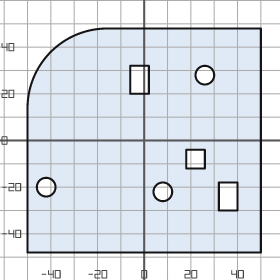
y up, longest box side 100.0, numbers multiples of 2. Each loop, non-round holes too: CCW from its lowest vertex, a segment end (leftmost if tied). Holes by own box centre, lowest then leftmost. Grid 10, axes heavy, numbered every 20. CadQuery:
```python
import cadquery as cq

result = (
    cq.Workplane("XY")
    .moveTo(-50.0, -48.0)
    .lineTo(50.0, -48.0)
    .lineTo(50.0, 48.0)
    .lineTo(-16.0, 48.0)
    .threePointArc((-40.0, 38.0), (-50.0, 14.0))
    .close()
    .moveTo(32.0, -30.0)
    .lineTo(40.0, -30.0)
    .lineTo(40.0, -18.0)
    .lineTo(32.0, -18.0)
    .close()
    .moveTo(8.0, -22.0)
    .circle(4.0)
    .moveTo(-42.0, -20.0)
    .circle(4.0)
    .moveTo(18.0, -12.0)
    .lineTo(26.0, -12.0)
    .lineTo(26.0, -4.0)
    .lineTo(18.0, -4.0)
    .close()
    .moveTo(-6.0, 20.0)
    .lineTo(2.0, 20.0)
    .lineTo(2.0, 32.0)
    .lineTo(-6.0, 32.0)
    .close()
    .moveTo(26.0, 28.0)
    .circle(4.0)
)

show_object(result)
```